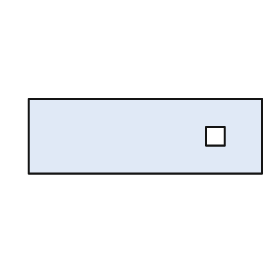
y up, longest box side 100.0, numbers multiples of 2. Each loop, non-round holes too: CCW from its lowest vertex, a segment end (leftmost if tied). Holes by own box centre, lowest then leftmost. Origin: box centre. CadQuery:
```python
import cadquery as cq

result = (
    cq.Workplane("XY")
    .moveTo(-50.0, -16.0)
    .lineTo(50.0, -16.0)
    .lineTo(50.0, 16.0)
    .lineTo(-50.0, 16.0)
    .close()
    .moveTo(26.0, -4.0)
    .lineTo(34.0, -4.0)
    .lineTo(34.0, 4.0)
    .lineTo(26.0, 4.0)
    .close()
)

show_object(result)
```